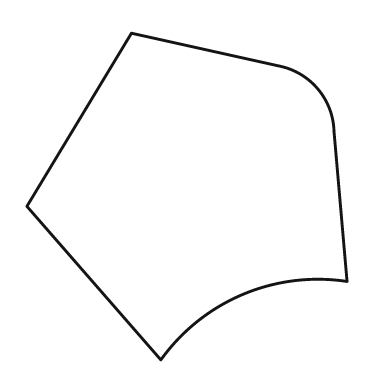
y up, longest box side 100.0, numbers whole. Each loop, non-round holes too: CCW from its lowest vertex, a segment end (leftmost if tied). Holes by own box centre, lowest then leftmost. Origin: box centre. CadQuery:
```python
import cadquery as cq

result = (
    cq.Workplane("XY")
    .moveTo(-8.0, -50.0)
    .threePointArc((17.0, -30.0), (49.0, -26.0))
    .lineTo(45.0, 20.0)
    .threePointArc((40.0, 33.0), (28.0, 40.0))
    .lineTo(-17.0, 50.0)
    .lineTo(-49.0, -3.0)
    .close()
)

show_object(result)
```